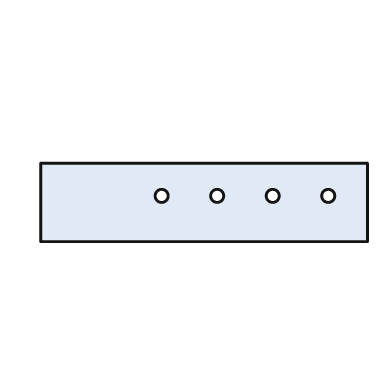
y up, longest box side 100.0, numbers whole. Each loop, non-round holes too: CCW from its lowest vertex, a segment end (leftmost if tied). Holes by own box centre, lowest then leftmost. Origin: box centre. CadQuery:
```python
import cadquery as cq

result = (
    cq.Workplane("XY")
    .moveTo(-50.0, -12.0)
    .lineTo(50.0, -12.0)
    .lineTo(50.0, 12.0)
    .lineTo(-50.0, 12.0)
    .close()
    .moveTo(-13.0, 2.0)
    .circle(2.0)
    .moveTo(4.0, 2.0)
    .circle(2.0)
    .moveTo(21.0, 2.0)
    .circle(2.0)
    .moveTo(38.0, 2.0)
    .circle(2.0)
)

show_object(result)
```